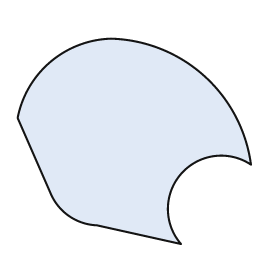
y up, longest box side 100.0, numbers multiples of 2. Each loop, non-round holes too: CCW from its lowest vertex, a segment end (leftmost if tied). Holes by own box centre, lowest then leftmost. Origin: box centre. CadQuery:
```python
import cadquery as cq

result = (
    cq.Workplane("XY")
    .moveTo(20.0, -44.0)
    .threePointArc((20.0, -14.0), (50.0, -10.0))
    .threePointArc((30.0, 28.0), (-10.0, 44.0))
    .threePointArc((-36.0, 34.0), (-50.0, 10.0))
    .lineTo(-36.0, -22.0)
    .threePointArc((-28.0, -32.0), (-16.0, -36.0))
    .close()
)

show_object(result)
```